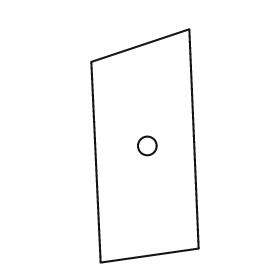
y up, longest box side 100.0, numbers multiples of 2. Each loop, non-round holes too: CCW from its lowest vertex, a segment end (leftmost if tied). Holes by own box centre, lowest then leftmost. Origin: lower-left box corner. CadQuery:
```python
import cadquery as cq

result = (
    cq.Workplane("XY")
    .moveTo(4.0, 0.0)
    .lineTo(46.0, 6.0)
    .lineTo(42.0, 100.0)
    .lineTo(0.0, 86.0)
    .close()
    .moveTo(24.0, 50.0)
    .circle(4.0)
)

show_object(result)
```